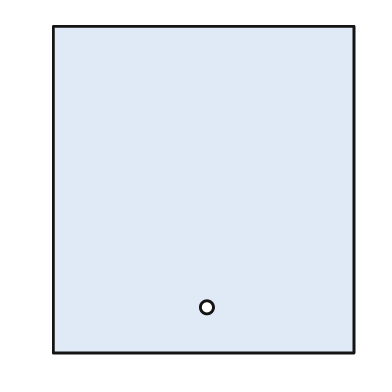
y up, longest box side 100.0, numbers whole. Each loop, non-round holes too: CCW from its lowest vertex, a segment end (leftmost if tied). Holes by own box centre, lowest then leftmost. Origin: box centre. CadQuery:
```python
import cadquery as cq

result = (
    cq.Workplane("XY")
    .moveTo(-46.0, -50.0)
    .lineTo(46.0, -50.0)
    .lineTo(46.0, 50.0)
    .lineTo(-46.0, 50.0)
    .close()
    .moveTo(1.0, -36.0)
    .circle(2.0)
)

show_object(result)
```